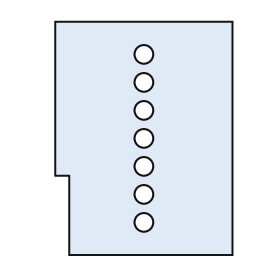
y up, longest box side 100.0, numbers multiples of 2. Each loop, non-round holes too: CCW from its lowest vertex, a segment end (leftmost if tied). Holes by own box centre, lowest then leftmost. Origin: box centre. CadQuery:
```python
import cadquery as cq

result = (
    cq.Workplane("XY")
    .moveTo(-32.0, -50.0)
    .lineTo(38.0, -50.0)
    .lineTo(38.0, 50.0)
    .lineTo(-38.0, 50.0)
    .lineTo(-38.0, -16.0)
    .lineTo(-32.0, -16.0)
    .close()
    .moveTo(0.0, -36.0)
    .circle(4.0)
    .moveTo(0.0, -24.0)
    .circle(4.0)
    .moveTo(0.0, -12.0)
    .circle(4.0)
    .moveTo(0.0, 0.0)
    .circle(4.0)
    .moveTo(0.0, 12.0)
    .circle(4.0)
    .moveTo(0.0, 24.0)
    .circle(4.0)
    .moveTo(0.0, 36.0)
    .circle(4.0)
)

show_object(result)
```